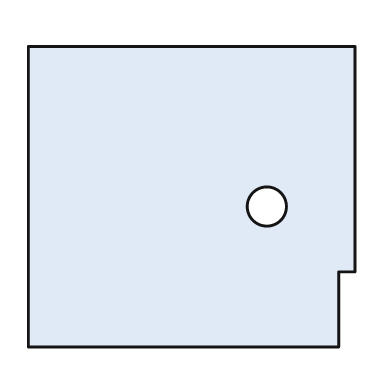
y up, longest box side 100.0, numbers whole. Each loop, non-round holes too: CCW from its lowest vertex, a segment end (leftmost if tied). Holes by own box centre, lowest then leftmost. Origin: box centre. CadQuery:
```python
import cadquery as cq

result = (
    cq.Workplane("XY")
    .moveTo(-50.0, -46.0)
    .lineTo(45.0, -46.0)
    .lineTo(45.0, -23.0)
    .lineTo(50.0, -23.0)
    .lineTo(50.0, 46.0)
    .lineTo(-50.0, 46.0)
    .close()
    .moveTo(23.0, -3.0)
    .circle(6.0)
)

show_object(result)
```